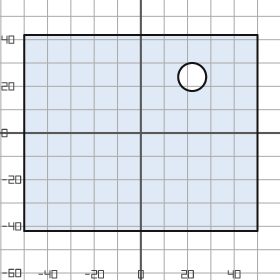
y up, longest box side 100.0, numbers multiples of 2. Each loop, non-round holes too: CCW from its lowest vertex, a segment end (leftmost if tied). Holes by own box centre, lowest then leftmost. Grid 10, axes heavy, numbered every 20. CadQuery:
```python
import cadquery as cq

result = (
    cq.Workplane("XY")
    .moveTo(-50.0, -42.0)
    .lineTo(50.0, -42.0)
    .lineTo(50.0, 42.0)
    .lineTo(-50.0, 42.0)
    .close()
    .moveTo(22.0, 24.0)
    .circle(6.0)
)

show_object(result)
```